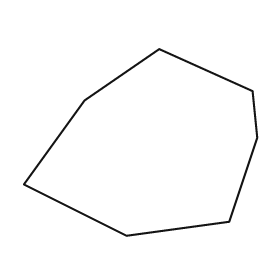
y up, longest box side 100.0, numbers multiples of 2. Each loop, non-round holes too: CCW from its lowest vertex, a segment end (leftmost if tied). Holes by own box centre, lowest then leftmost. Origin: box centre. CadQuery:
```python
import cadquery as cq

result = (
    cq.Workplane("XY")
    .moveTo(-6.0, -40.0)
    .lineTo(38.0, -34.0)
    .lineTo(50.0, 2.0)
    .lineTo(48.0, 22.0)
    .lineTo(8.0, 40.0)
    .lineTo(-24.0, 18.0)
    .lineTo(-50.0, -18.0)
    .close()
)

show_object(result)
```